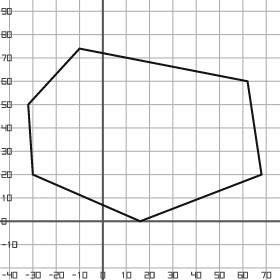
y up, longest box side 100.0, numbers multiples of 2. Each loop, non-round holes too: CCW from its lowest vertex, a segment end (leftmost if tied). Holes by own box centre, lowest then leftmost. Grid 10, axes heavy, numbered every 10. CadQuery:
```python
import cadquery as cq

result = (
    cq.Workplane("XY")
    .moveTo(16.0, 0.0)
    .lineTo(68.0, 20.0)
    .lineTo(62.0, 60.0)
    .lineTo(-10.0, 74.0)
    .lineTo(-32.0, 50.0)
    .lineTo(-30.0, 20.0)
    .close()
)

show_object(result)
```